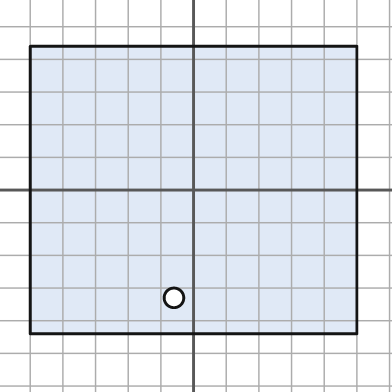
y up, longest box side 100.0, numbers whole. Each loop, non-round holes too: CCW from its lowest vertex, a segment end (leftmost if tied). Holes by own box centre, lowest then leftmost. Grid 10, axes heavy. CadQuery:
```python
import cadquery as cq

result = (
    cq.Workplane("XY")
    .moveTo(-50.0, -44.0)
    .lineTo(50.0, -44.0)
    .lineTo(50.0, 44.0)
    .lineTo(-50.0, 44.0)
    .close()
    .moveTo(-6.0, -33.0)
    .circle(3.0)
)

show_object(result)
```